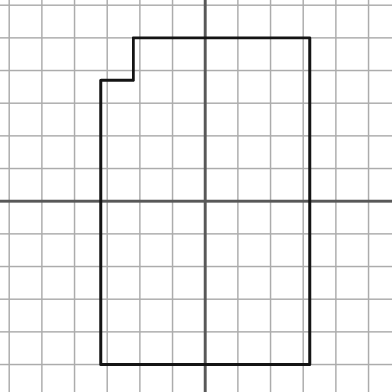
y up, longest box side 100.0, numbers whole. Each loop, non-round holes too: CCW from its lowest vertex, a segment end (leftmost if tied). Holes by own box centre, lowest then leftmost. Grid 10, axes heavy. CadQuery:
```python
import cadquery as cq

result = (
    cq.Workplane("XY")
    .moveTo(-32.0, -50.0)
    .lineTo(32.0, -50.0)
    .lineTo(32.0, 50.0)
    .lineTo(-22.0, 50.0)
    .lineTo(-22.0, 37.0)
    .lineTo(-32.0, 37.0)
    .close()
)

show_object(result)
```